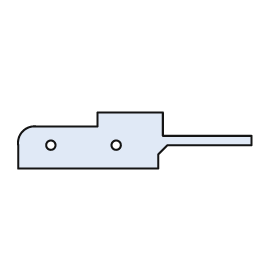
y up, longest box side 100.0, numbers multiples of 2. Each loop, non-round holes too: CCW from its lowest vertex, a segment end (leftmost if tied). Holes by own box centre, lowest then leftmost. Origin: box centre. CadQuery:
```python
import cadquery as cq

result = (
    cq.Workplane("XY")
    .moveTo(-50.0, -12.0)
    .lineTo(10.0, -12.0)
    .lineTo(10.0, -6.0)
    .lineTo(14.0, -2.0)
    .lineTo(50.0, -2.0)
    .lineTo(50.0, 2.0)
    .lineTo(12.0, 2.0)
    .lineTo(12.0, 12.0)
    .lineTo(-16.0, 12.0)
    .lineTo(-16.0, 6.0)
    .lineTo(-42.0, 6.0)
    .threePointArc((-48.0, 4.0), (-50.0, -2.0))
    .close()
    .moveTo(-36.0, -2.0)
    .circle(2.0)
    .moveTo(-8.0, -2.0)
    .circle(2.0)
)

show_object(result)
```